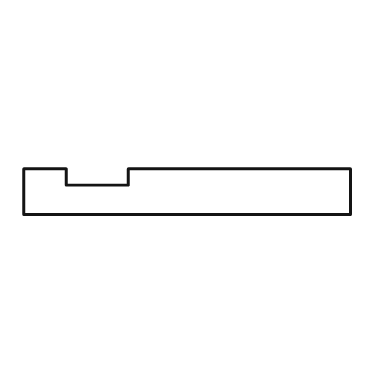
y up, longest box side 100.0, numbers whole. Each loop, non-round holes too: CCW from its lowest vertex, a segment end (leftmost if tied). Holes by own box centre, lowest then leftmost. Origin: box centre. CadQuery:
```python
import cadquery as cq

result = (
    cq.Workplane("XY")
    .moveTo(-50.0, -7.0)
    .lineTo(50.0, -7.0)
    .lineTo(50.0, 7.0)
    .lineTo(-18.0, 7.0)
    .lineTo(-18.0, 2.0)
    .lineTo(-37.0, 2.0)
    .lineTo(-37.0, 7.0)
    .lineTo(-50.0, 7.0)
    .close()
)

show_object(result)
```